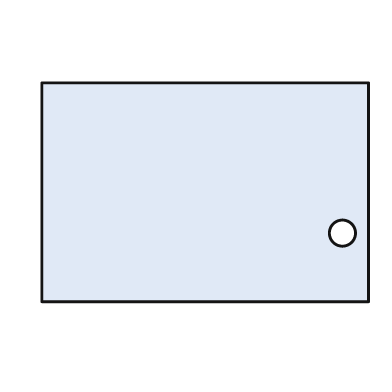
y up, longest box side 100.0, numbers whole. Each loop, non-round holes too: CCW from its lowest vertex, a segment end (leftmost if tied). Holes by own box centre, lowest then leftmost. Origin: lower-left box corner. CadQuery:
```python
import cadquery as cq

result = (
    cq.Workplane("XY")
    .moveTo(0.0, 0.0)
    .lineTo(100.0, 0.0)
    .lineTo(100.0, 67.0)
    .lineTo(0.0, 67.0)
    .close()
    .moveTo(92.0, 21.0)
    .circle(4.0)
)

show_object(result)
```